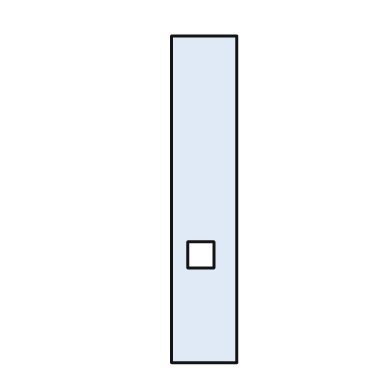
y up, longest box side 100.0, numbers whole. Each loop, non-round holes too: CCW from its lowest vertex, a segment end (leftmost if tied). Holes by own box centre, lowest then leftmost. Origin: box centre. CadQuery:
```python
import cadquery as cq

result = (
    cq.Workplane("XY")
    .moveTo(-10.0, -50.0)
    .lineTo(10.0, -50.0)
    .lineTo(10.0, 50.0)
    .lineTo(-10.0, 50.0)
    .close()
    .moveTo(-5.0, -21.0)
    .lineTo(3.0, -21.0)
    .lineTo(3.0, -13.0)
    .lineTo(-5.0, -13.0)
    .close()
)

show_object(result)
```